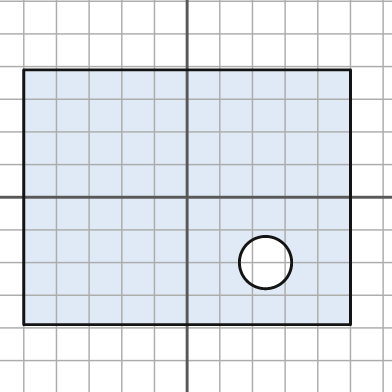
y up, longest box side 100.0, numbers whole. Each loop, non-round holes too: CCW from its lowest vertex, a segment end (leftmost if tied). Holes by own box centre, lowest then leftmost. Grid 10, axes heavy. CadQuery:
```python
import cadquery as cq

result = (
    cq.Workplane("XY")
    .moveTo(-50.0, -39.0)
    .lineTo(50.0, -39.0)
    .lineTo(50.0, 39.0)
    .lineTo(-50.0, 39.0)
    .close()
    .moveTo(24.0, -20.0)
    .circle(8.0)
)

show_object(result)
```